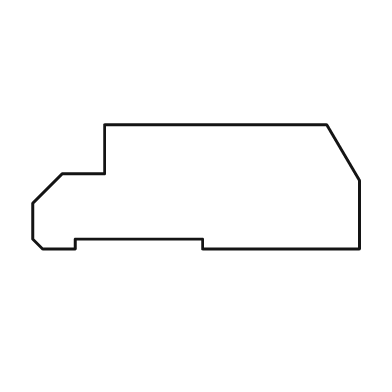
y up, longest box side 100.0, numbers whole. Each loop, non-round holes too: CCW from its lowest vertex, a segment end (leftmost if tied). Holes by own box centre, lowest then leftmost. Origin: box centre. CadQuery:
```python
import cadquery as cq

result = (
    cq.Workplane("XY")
    .moveTo(-47.0, -19.0)
    .lineTo(-37.0, -19.0)
    .lineTo(-37.0, -16.0)
    .lineTo(2.0, -16.0)
    .lineTo(2.0, -19.0)
    .lineTo(50.0, -19.0)
    .lineTo(50.0, 2.0)
    .lineTo(40.0, 19.0)
    .lineTo(-28.0, 19.0)
    .lineTo(-28.0, 4.0)
    .lineTo(-41.0, 4.0)
    .lineTo(-50.0, -5.0)
    .lineTo(-50.0, -16.0)
    .close()
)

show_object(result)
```